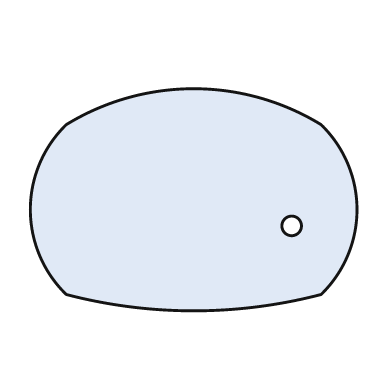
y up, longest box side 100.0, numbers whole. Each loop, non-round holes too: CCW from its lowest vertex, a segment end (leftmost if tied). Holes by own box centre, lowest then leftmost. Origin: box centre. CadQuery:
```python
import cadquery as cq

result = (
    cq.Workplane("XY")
    .moveTo(-39.0, -29.0)
    .threePointArc((0.0, -34.0), (39.0, -29.0))
    .threePointArc((50.0, -3.0), (39.0, 23.0))
    .threePointArc((0.0, 34.0), (-39.0, 23.0))
    .threePointArc((-50.0, -3.0), (-39.0, -29.0))
    .close()
    .moveTo(30.0, -8.0)
    .circle(3.0)
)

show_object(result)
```